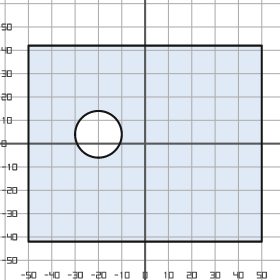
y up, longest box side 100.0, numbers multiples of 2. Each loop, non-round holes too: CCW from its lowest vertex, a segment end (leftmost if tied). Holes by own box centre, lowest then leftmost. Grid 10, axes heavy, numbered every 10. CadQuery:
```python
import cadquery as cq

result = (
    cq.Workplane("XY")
    .moveTo(-50.0, -42.0)
    .lineTo(50.0, -42.0)
    .lineTo(50.0, 42.0)
    .lineTo(-50.0, 42.0)
    .close()
    .moveTo(-20.0, 4.0)
    .circle(10.0)
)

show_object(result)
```